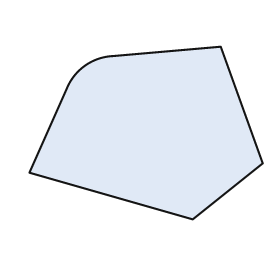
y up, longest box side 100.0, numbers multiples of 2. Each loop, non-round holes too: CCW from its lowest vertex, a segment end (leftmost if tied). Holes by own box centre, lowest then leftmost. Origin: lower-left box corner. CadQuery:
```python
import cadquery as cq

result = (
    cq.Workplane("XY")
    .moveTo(70.0, 0.0)
    .lineTo(100.0, 24.0)
    .lineTo(82.0, 74.0)
    .lineTo(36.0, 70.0)
    .threePointArc((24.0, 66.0), (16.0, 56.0))
    .lineTo(0.0, 20.0)
    .close()
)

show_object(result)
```